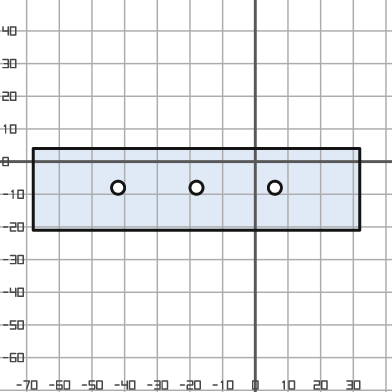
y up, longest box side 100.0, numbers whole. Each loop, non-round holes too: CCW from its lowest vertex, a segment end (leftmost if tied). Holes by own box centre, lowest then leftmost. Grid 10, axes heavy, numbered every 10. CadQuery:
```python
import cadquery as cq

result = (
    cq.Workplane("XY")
    .moveTo(-68.0, -21.0)
    .lineTo(32.0, -21.0)
    .lineTo(32.0, 4.0)
    .lineTo(-68.0, 4.0)
    .close()
    .moveTo(-42.0, -8.0)
    .circle(2.0)
    .moveTo(-18.0, -8.0)
    .circle(2.0)
    .moveTo(6.0, -8.0)
    .circle(2.0)
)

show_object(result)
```